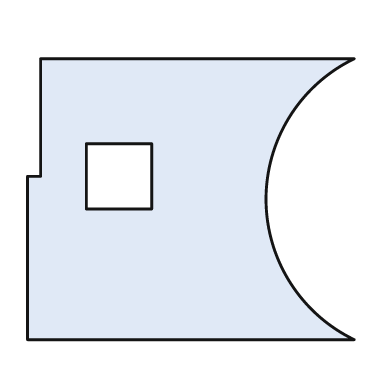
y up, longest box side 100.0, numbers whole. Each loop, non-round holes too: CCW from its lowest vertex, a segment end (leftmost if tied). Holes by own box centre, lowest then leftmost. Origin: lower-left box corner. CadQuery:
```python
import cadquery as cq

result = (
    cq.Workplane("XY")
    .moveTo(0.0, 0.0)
    .lineTo(100.0, 0.0)
    .threePointArc((73.0, 43.0), (100.0, 86.0))
    .lineTo(4.0, 86.0)
    .lineTo(4.0, 50.0)
    .lineTo(0.0, 50.0)
    .close()
    .moveTo(18.0, 40.0)
    .lineTo(38.0, 40.0)
    .lineTo(38.0, 60.0)
    .lineTo(18.0, 60.0)
    .close()
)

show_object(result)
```